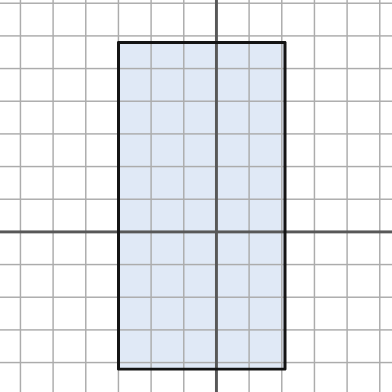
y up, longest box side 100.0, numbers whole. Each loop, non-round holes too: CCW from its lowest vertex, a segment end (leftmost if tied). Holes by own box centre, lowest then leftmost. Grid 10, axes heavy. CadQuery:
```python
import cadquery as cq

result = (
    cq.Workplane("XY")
    .moveTo(-30.0, -42.0)
    .lineTo(21.0, -42.0)
    .lineTo(21.0, 58.0)
    .lineTo(-30.0, 58.0)
    .close()
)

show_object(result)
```